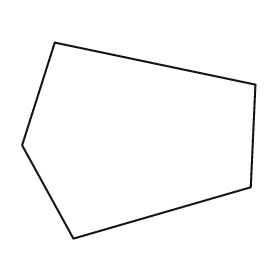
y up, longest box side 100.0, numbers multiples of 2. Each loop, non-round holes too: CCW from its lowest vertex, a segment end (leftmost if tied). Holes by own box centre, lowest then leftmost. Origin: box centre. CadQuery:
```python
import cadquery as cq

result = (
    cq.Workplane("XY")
    .moveTo(-28.0, -42.0)
    .lineTo(48.0, -20.0)
    .lineTo(50.0, 24.0)
    .lineTo(-36.0, 42.0)
    .lineTo(-50.0, -2.0)
    .close()
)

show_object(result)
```